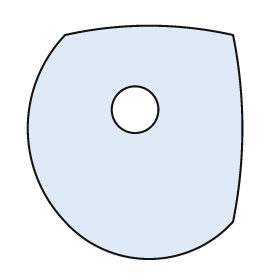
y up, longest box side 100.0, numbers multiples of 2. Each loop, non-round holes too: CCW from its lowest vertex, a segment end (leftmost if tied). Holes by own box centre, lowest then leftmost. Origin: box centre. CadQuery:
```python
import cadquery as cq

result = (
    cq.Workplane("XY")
    .moveTo(-30.0, -34.0)
    .threePointArc((6.0, -50.0), (42.0, -34.0))
    .threePointArc((46.0, 6.0), (42.0, 46.0))
    .threePointArc((6.0, 50.0), (-30.0, 46.0))
    .threePointArc((-46.0, 6.0), (-30.0, -34.0))
    .close()
    .moveTo(0.0, 14.0)
    .circle(10.0)
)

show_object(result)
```